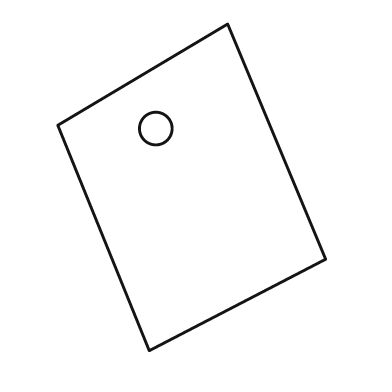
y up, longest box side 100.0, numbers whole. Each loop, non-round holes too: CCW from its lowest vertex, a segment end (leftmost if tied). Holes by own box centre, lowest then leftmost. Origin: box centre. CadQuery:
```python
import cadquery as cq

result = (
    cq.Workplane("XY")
    .moveTo(-13.0, -50.0)
    .lineTo(41.0, -22.0)
    .lineTo(11.0, 50.0)
    .lineTo(-41.0, 19.0)
    .close()
    .moveTo(-11.0, 18.0)
    .circle(5.0)
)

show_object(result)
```